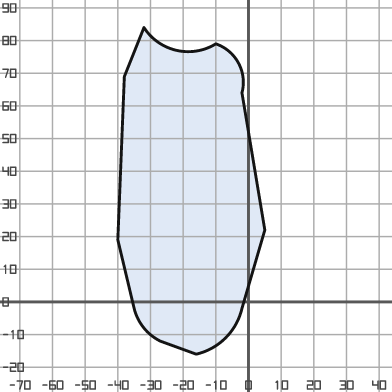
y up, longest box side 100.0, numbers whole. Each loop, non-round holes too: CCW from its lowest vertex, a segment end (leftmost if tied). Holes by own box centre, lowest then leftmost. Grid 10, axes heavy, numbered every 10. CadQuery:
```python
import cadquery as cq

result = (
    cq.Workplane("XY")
    .moveTo(-16.0, -16.0)
    .threePointArc((-7.0, -11.0), (-2.0, -2.0))
    .lineTo(5.0, 22.0)
    .lineTo(-2.0, 64.0)
    .threePointArc((-3.0, 73.0), (-10.0, 79.0))
    .threePointArc((-22.0, 77.0), (-32.0, 84.0))
    .lineTo(-38.0, 69.0)
    .lineTo(-40.0, 19.0)
    .lineTo(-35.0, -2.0)
    .threePointArc((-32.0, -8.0), (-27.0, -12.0))
    .close()
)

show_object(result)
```